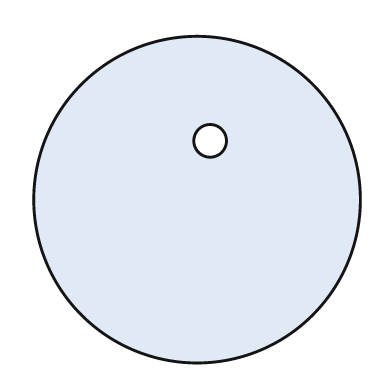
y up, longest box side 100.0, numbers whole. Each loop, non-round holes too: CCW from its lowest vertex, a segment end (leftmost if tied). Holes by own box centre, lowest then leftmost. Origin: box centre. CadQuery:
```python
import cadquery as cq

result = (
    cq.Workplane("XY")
    .moveTo(0.0, 0.0)
    .circle(50.0)
    .moveTo(4.0, 18.0)
    .circle(5.0)
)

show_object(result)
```